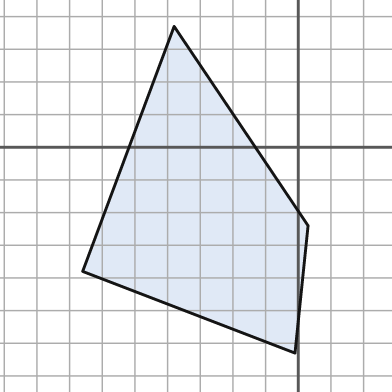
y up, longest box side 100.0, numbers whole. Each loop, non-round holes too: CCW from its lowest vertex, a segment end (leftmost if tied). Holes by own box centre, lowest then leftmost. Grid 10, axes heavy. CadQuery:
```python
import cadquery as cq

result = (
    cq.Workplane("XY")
    .moveTo(-1.0, -63.0)
    .lineTo(3.0, -24.0)
    .lineTo(-38.0, 37.0)
    .lineTo(-66.0, -38.0)
    .close()
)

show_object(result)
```